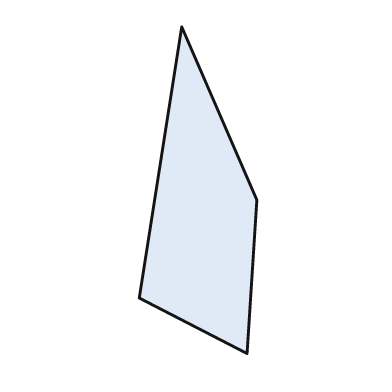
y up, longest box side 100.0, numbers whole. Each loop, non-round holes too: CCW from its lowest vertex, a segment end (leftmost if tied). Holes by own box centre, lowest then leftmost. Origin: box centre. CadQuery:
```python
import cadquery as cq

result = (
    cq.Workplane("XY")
    .moveTo(15.0, -50.0)
    .lineTo(18.0, -3.0)
    .lineTo(-5.0, 50.0)
    .lineTo(-18.0, -33.0)
    .close()
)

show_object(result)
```